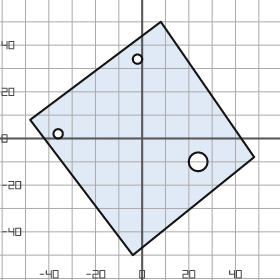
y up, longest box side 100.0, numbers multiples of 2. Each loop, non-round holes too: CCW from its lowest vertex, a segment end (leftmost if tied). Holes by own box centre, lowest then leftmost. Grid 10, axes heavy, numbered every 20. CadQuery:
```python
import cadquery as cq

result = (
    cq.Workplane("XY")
    .moveTo(-4.0, -50.0)
    .lineTo(48.0, -8.0)
    .lineTo(8.0, 50.0)
    .lineTo(-48.0, 8.0)
    .close()
    .moveTo(24.0, -10.0)
    .circle(4.0)
    .moveTo(-36.0, 2.0)
    .circle(2.0)
    .moveTo(-2.0, 34.0)
    .circle(2.0)
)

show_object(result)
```